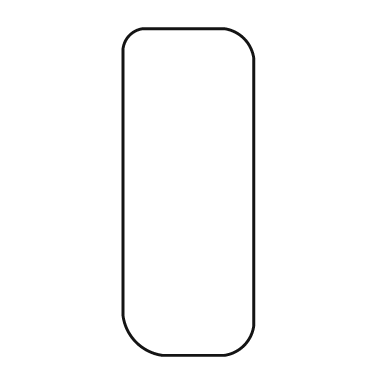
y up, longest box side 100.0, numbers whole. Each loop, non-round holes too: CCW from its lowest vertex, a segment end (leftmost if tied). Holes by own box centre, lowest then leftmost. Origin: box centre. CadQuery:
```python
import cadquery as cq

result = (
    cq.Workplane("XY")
    .moveTo(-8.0, -50.0)
    .lineTo(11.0, -50.0)
    .threePointArc((17.0, -47.0), (20.0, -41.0))
    .lineTo(20.0, 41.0)
    .threePointArc((17.0, 47.0), (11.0, 50.0))
    .lineTo(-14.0, 50.0)
    .threePointArc((-18.0, 48.0), (-20.0, 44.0))
    .lineTo(-20.0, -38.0)
    .threePointArc((-16.0, -46.0), (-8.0, -50.0))
    .close()
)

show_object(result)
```